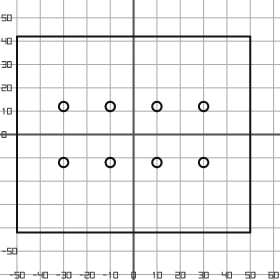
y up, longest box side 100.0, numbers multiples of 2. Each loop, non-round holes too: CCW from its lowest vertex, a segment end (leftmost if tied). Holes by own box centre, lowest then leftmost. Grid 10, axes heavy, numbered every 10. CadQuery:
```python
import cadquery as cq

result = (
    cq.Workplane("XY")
    .moveTo(-50.0, -42.0)
    .lineTo(50.0, -42.0)
    .lineTo(50.0, 42.0)
    .lineTo(-50.0, 42.0)
    .close()
    .moveTo(-30.0, -12.0)
    .circle(2.0)
    .moveTo(-10.0, -12.0)
    .circle(2.0)
    .moveTo(10.0, -12.0)
    .circle(2.0)
    .moveTo(30.0, -12.0)
    .circle(2.0)
    .moveTo(-30.0, 12.0)
    .circle(2.0)
    .moveTo(-10.0, 12.0)
    .circle(2.0)
    .moveTo(10.0, 12.0)
    .circle(2.0)
    .moveTo(30.0, 12.0)
    .circle(2.0)
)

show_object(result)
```